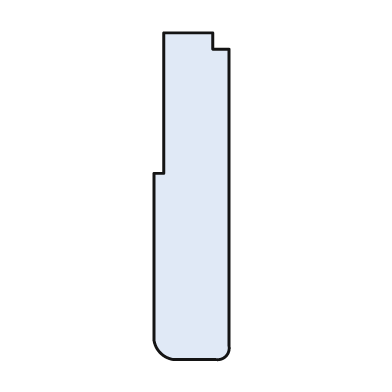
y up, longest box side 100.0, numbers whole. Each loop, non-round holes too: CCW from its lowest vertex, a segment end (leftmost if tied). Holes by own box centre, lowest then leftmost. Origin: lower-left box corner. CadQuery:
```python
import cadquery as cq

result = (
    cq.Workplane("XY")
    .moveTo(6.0, 0.0)
    .lineTo(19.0, 0.0)
    .threePointArc((22.0, 1.0), (23.0, 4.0))
    .lineTo(23.0, 95.0)
    .lineTo(18.0, 95.0)
    .lineTo(18.0, 100.0)
    .lineTo(3.0, 100.0)
    .lineTo(3.0, 57.0)
    .lineTo(0.0, 57.0)
    .lineTo(0.0, 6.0)
    .threePointArc((2.0, 2.0), (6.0, 0.0))
    .close()
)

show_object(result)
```